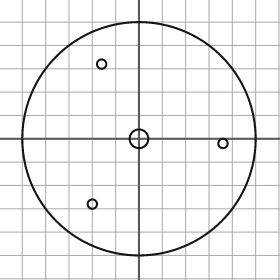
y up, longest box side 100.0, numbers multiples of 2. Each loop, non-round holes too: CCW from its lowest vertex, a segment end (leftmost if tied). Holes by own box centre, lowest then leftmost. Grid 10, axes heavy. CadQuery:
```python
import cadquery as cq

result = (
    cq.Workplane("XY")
    .moveTo(0.0, 0.0)
    .circle(50.0)
    .moveTo(-20.0, -28.0)
    .circle(2.0)
    .moveTo(36.0, -2.0)
    .circle(2.0)
    .moveTo(0.0, 0.0)
    .circle(4.0)
    .moveTo(-16.0, 32.0)
    .circle(2.0)
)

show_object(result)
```